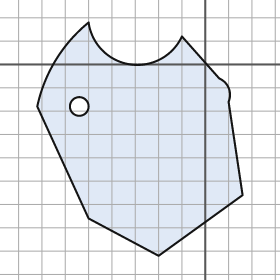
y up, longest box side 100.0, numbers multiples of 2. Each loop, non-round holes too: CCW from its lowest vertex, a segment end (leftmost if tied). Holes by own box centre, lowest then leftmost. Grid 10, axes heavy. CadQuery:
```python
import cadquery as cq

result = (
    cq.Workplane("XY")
    .moveTo(-20.0, -82.0)
    .lineTo(16.0, -56.0)
    .lineTo(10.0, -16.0)
    .threePointArc((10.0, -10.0), (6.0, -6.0))
    .lineTo(-10.0, 12.0)
    .threePointArc((-32.0, 0.0), (-50.0, 18.0))
    .threePointArc((-64.0, 2.0), (-72.0, -18.0))
    .lineTo(-50.0, -66.0)
    .close()
    .moveTo(-54.0, -18.0)
    .circle(4.0)
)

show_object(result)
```